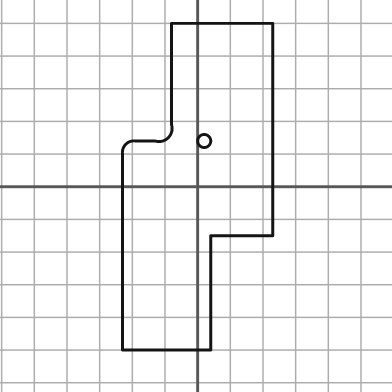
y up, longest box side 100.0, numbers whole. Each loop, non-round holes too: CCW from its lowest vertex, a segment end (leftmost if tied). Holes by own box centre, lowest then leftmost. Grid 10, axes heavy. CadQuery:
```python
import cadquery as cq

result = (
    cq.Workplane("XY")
    .moveTo(-23.0, -50.0)
    .lineTo(4.0, -50.0)
    .lineTo(4.0, -15.0)
    .lineTo(23.0, -15.0)
    .lineTo(23.0, 50.0)
    .lineTo(-8.0, 50.0)
    .lineTo(-8.0, 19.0)
    .threePointArc((-9.0, 15.0), (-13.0, 14.0))
    .lineTo(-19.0, 14.0)
    .threePointArc((-22.0, 13.0), (-23.0, 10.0))
    .close()
    .moveTo(2.0, 14.0)
    .circle(2.0)
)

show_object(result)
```